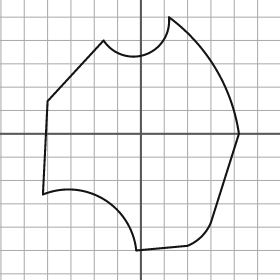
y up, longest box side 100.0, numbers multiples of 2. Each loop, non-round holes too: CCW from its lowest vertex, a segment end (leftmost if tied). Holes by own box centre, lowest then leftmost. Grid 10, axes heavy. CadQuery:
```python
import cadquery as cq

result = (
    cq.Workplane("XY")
    .moveTo(-2.0, -50.0)
    .lineTo(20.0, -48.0)
    .threePointArc((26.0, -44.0), (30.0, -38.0))
    .lineTo(42.0, 0.0)
    .threePointArc((32.0, 28.0), (12.0, 50.0))
    .threePointArc((2.0, 34.0), (-16.0, 40.0))
    .lineTo(-40.0, 14.0)
    .lineTo(-42.0, -26.0)
    .threePointArc((-16.0, -28.0), (-2.0, -50.0))
    .close()
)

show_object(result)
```